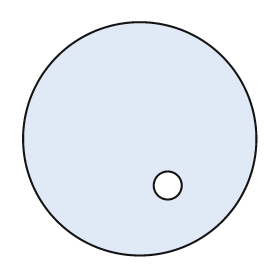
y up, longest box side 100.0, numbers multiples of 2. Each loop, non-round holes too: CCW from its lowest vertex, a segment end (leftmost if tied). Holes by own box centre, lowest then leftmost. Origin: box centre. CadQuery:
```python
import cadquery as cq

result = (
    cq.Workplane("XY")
    .moveTo(0.0, 0.0)
    .circle(50.0)
    .moveTo(12.0, -20.0)
    .circle(6.0)
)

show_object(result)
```